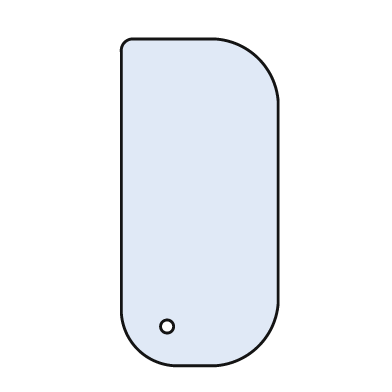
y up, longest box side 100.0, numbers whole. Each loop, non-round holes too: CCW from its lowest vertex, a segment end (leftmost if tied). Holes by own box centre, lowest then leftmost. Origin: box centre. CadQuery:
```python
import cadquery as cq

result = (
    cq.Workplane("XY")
    .moveTo(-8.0, -50.0)
    .lineTo(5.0, -50.0)
    .threePointArc((18.0, -44.0), (24.0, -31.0))
    .lineTo(24.0, 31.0)
    .threePointArc((18.0, 44.0), (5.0, 50.0))
    .lineTo(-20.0, 50.0)
    .threePointArc((-23.0, 49.0), (-24.0, 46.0))
    .lineTo(-24.0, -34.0)
    .threePointArc((-19.0, -45.0), (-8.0, -50.0))
    .close()
    .moveTo(-10.0, -38.0)
    .circle(2.0)
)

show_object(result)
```